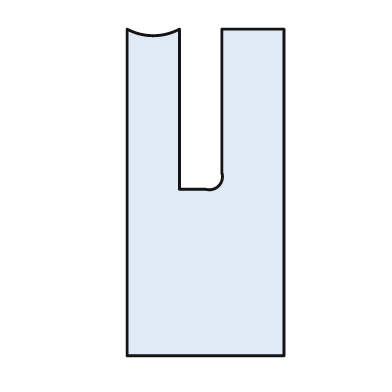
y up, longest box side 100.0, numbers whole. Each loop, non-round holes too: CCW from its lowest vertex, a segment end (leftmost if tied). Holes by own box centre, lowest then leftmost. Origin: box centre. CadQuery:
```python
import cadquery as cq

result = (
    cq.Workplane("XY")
    .moveTo(-24.0, -50.0)
    .lineTo(24.0, -50.0)
    .lineTo(24.0, 50.0)
    .lineTo(5.0, 50.0)
    .lineTo(5.0, 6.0)
    .threePointArc((4.0, 2.0), (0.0, 1.0))
    .lineTo(-8.0, 1.0)
    .lineTo(-8.0, 50.0)
    .threePointArc((-16.0, 48.0), (-24.0, 50.0))
    .close()
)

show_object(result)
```